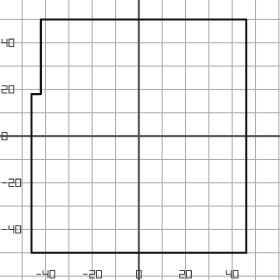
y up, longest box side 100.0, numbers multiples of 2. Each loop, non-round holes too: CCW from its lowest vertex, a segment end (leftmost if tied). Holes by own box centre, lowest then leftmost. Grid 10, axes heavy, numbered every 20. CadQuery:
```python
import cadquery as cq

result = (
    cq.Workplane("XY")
    .moveTo(-46.0, -50.0)
    .lineTo(46.0, -50.0)
    .lineTo(46.0, 50.0)
    .lineTo(-42.0, 50.0)
    .lineTo(-42.0, 18.0)
    .lineTo(-46.0, 18.0)
    .close()
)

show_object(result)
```